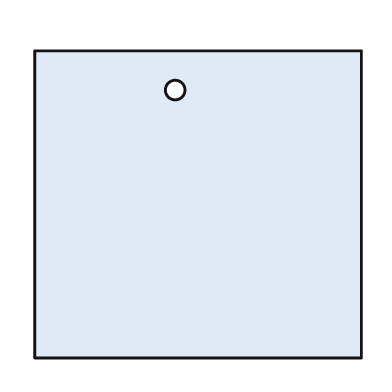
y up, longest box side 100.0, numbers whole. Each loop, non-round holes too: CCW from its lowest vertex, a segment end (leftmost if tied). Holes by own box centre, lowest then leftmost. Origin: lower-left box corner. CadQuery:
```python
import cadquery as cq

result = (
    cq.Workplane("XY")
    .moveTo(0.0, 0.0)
    .lineTo(100.0, 0.0)
    .lineTo(100.0, 94.0)
    .lineTo(0.0, 94.0)
    .close()
    .moveTo(43.0, 82.0)
    .circle(3.0)
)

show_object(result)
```